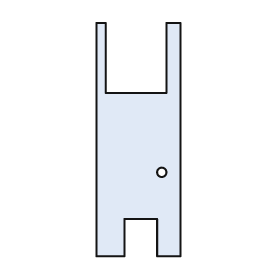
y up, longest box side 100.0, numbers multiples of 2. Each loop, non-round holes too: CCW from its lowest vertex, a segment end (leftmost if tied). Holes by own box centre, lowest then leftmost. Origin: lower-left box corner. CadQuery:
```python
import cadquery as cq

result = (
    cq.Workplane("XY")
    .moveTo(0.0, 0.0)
    .lineTo(12.0, 0.0)
    .lineTo(12.0, 16.0)
    .lineTo(26.0, 16.0)
    .lineTo(26.0, 0.0)
    .lineTo(36.0, 0.0)
    .lineTo(36.0, 100.0)
    .lineTo(30.0, 100.0)
    .lineTo(30.0, 70.0)
    .lineTo(4.0, 70.0)
    .lineTo(4.0, 100.0)
    .lineTo(0.0, 100.0)
    .close()
    .moveTo(28.0, 36.0)
    .circle(2.0)
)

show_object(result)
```